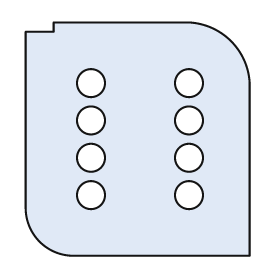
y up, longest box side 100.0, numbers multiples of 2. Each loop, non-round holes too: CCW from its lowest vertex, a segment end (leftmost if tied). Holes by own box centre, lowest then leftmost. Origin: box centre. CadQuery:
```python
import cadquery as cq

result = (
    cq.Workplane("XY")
    .moveTo(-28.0, -50.0)
    .lineTo(48.0, -50.0)
    .lineTo(48.0, 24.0)
    .threePointArc((40.0, 42.0), (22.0, 50.0))
    .lineTo(-36.0, 50.0)
    .lineTo(-36.0, 46.0)
    .lineTo(-48.0, 46.0)
    .lineTo(-48.0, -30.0)
    .threePointArc((-42.0, -44.0), (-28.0, -50.0))
    .close()
    .moveTo(-20.0, -24.0)
    .circle(6.0)
    .moveTo(22.0, -24.0)
    .circle(6.0)
    .moveTo(-20.0, -8.0)
    .circle(6.0)
    .moveTo(22.0, -8.0)
    .circle(6.0)
    .moveTo(-20.0, 8.0)
    .circle(6.0)
    .moveTo(22.0, 8.0)
    .circle(6.0)
    .moveTo(-20.0, 24.0)
    .circle(6.0)
    .moveTo(22.0, 24.0)
    .circle(6.0)
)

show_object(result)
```